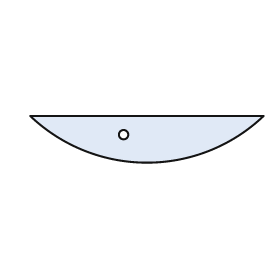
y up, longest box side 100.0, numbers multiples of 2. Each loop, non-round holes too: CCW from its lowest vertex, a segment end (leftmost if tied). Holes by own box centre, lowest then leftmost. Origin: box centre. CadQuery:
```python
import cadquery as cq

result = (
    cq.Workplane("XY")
    .moveTo(-50.0, 10.0)
    .threePointArc((0.0, -10.0), (50.0, 10.0))
    .close()
    .moveTo(-10.0, 2.0)
    .circle(2.0)
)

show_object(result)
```